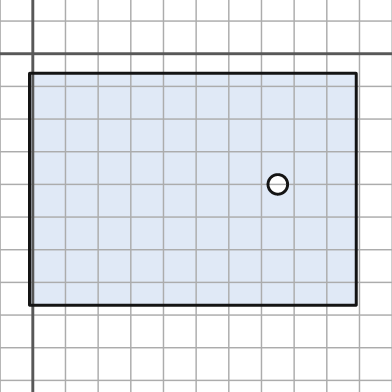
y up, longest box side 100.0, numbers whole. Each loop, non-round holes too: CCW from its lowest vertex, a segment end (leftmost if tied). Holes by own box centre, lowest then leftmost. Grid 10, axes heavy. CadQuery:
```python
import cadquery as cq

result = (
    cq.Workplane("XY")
    .moveTo(-1.0, -77.0)
    .lineTo(99.0, -77.0)
    .lineTo(99.0, -6.0)
    .lineTo(-1.0, -6.0)
    .close()
    .moveTo(75.0, -40.0)
    .circle(3.0)
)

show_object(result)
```